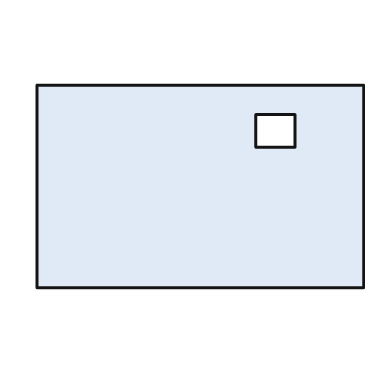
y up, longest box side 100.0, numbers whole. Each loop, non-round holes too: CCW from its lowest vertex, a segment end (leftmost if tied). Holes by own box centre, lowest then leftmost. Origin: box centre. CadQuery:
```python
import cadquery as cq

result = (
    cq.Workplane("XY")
    .moveTo(-50.0, -31.0)
    .lineTo(50.0, -31.0)
    .lineTo(50.0, 31.0)
    .lineTo(-50.0, 31.0)
    .close()
    .moveTo(17.0, 12.0)
    .lineTo(29.0, 12.0)
    .lineTo(29.0, 22.0)
    .lineTo(17.0, 22.0)
    .close()
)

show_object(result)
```